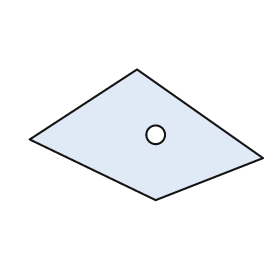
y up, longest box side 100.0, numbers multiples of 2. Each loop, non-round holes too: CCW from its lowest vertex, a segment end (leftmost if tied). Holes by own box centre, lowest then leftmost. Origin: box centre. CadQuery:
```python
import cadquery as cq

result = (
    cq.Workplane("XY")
    .moveTo(4.0, -28.0)
    .lineTo(50.0, -10.0)
    .lineTo(-4.0, 28.0)
    .lineTo(-50.0, -2.0)
    .close()
    .moveTo(4.0, 0.0)
    .circle(4.0)
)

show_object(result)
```